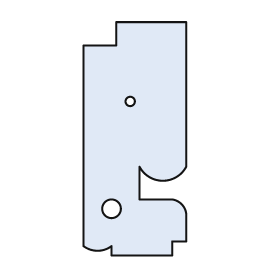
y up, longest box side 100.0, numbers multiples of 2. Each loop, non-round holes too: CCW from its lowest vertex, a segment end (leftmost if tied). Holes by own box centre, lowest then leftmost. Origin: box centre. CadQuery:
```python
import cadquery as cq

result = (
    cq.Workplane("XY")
    .moveTo(-10.0, -50.0)
    .lineTo(16.0, -50.0)
    .lineTo(16.0, -44.0)
    .lineTo(22.0, -44.0)
    .lineTo(22.0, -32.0)
    .threePointArc((20.0, -28.0), (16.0, -26.0))
    .lineTo(2.0, -26.0)
    .lineTo(2.0, -12.0)
    .threePointArc((12.0, -18.0), (22.0, -12.0))
    .lineTo(22.0, 50.0)
    .lineTo(-8.0, 50.0)
    .lineTo(-8.0, 40.0)
    .lineTo(-22.0, 40.0)
    .lineTo(-22.0, -46.0)
    .threePointArc((-16.0, -48.0), (-10.0, -46.0))
    .close()
    .moveTo(-10.0, -30.0)
    .circle(4.0)
    .moveTo(-2.0, 16.0)
    .circle(2.0)
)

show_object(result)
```